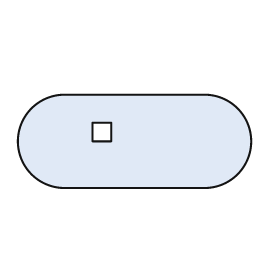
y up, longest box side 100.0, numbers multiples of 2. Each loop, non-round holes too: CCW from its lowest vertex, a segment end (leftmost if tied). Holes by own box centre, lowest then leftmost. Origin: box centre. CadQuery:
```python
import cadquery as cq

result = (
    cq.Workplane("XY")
    .moveTo(-30.0, -20.0)
    .lineTo(30.0, -20.0)
    .threePointArc((50.0, 0.0), (30.0, 20.0))
    .lineTo(-30.0, 20.0)
    .threePointArc((-50.0, 0.0), (-30.0, -20.0))
    .close()
    .moveTo(-18.0, 0.0)
    .lineTo(-10.0, 0.0)
    .lineTo(-10.0, 8.0)
    .lineTo(-18.0, 8.0)
    .close()
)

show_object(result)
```